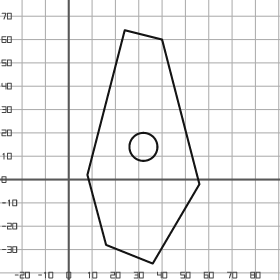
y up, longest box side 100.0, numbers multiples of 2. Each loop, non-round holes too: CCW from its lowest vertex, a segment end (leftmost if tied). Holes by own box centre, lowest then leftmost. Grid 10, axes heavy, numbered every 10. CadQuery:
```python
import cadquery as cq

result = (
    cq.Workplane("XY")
    .moveTo(36.0, -36.0)
    .lineTo(56.0, -2.0)
    .lineTo(40.0, 60.0)
    .lineTo(24.0, 64.0)
    .lineTo(8.0, 2.0)
    .lineTo(16.0, -28.0)
    .close()
    .moveTo(32.0, 14.0)
    .circle(6.0)
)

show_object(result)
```